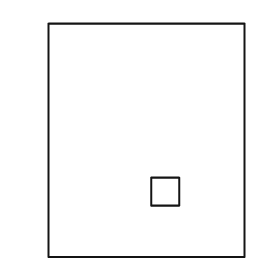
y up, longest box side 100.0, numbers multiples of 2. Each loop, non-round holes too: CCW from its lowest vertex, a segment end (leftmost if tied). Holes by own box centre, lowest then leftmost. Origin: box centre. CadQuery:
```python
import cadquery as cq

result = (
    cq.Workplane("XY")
    .moveTo(-42.0, -50.0)
    .lineTo(42.0, -50.0)
    .lineTo(42.0, 50.0)
    .lineTo(-42.0, 50.0)
    .close()
    .moveTo(2.0, -28.0)
    .lineTo(14.0, -28.0)
    .lineTo(14.0, -16.0)
    .lineTo(2.0, -16.0)
    .close()
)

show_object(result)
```